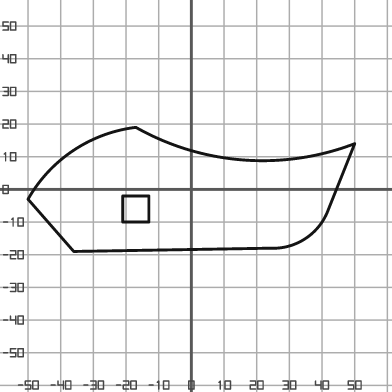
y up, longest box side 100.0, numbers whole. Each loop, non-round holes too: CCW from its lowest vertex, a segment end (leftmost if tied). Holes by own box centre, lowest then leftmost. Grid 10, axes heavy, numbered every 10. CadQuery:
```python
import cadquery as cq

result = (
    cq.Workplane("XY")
    .moveTo(-36.0, -19.0)
    .lineTo(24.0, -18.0)
    .threePointArc((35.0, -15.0), (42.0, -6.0))
    .lineTo(50.0, 14.0)
    .threePointArc((16.0, 9.0), (-17.0, 19.0))
    .threePointArc((-36.0, 12.0), (-50.0, -3.0))
    .close()
    .moveTo(-21.0, -10.0)
    .lineTo(-13.0, -10.0)
    .lineTo(-13.0, -2.0)
    .lineTo(-21.0, -2.0)
    .close()
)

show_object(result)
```